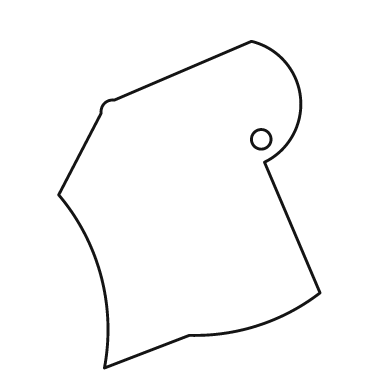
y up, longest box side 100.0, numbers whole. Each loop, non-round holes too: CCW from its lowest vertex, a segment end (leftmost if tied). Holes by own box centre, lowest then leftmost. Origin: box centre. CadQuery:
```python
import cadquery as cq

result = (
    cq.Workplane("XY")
    .moveTo(-26.0, -50.0)
    .lineTo(0.0, -40.0)
    .threePointArc((21.0, -37.0), (40.0, -27.0))
    .lineTo(23.0, 13.0)
    .threePointArc((34.0, 33.0), (19.0, 50.0))
    .lineTo(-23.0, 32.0)
    .threePointArc((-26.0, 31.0), (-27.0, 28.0))
    .lineTo(-40.0, 3.0)
    .threePointArc((-27.0, -22.0), (-26.0, -50.0))
    .close()
    .moveTo(22.0, 20.0)
    .circle(3.0)
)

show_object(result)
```